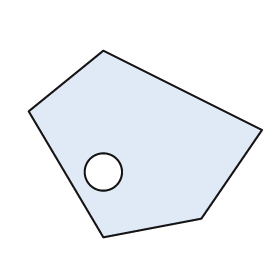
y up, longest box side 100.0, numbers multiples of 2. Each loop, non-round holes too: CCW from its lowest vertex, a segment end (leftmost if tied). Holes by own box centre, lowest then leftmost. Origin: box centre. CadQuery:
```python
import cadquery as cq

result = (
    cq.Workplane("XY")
    .moveTo(-18.0, -40.0)
    .lineTo(24.0, -32.0)
    .lineTo(50.0, 6.0)
    .lineTo(-18.0, 40.0)
    .lineTo(-50.0, 14.0)
    .close()
    .moveTo(-18.0, -12.0)
    .circle(8.0)
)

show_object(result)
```